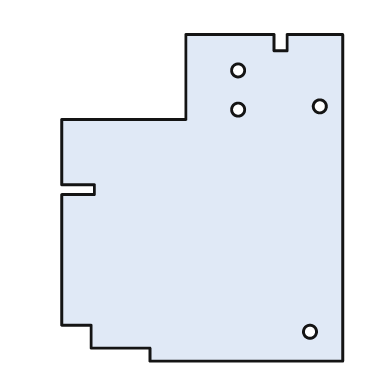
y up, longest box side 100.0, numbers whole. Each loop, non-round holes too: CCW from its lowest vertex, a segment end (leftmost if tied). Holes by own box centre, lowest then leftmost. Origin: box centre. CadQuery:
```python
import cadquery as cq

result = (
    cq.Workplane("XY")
    .moveTo(-16.0, -50.0)
    .lineTo(43.0, -50.0)
    .lineTo(43.0, 50.0)
    .lineTo(26.0, 50.0)
    .lineTo(26.0, 45.0)
    .lineTo(22.0, 45.0)
    .lineTo(22.0, 50.0)
    .lineTo(-5.0, 50.0)
    .lineTo(-5.0, 24.0)
    .lineTo(-43.0, 24.0)
    .lineTo(-43.0, 4.0)
    .lineTo(-33.0, 4.0)
    .lineTo(-33.0, 1.0)
    .lineTo(-43.0, 1.0)
    .lineTo(-43.0, -39.0)
    .lineTo(-34.0, -39.0)
    .lineTo(-34.0, -46.0)
    .lineTo(-16.0, -46.0)
    .close()
    .moveTo(33.0, -41.0)
    .circle(2.0)
    .moveTo(11.0, 27.0)
    .circle(2.0)
    .moveTo(36.0, 28.0)
    .circle(2.0)
    .moveTo(11.0, 39.0)
    .circle(2.0)
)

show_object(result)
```